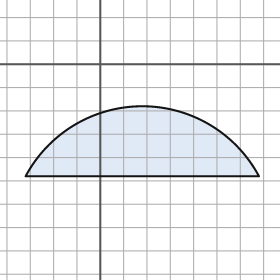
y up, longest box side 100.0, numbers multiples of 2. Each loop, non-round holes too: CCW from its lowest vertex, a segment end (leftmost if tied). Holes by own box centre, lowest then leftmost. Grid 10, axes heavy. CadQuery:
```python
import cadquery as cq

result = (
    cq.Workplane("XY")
    .moveTo(-32.0, -48.0)
    .lineTo(68.0, -48.0)
    .threePointArc((18.0, -18.0), (-32.0, -48.0))
    .close()
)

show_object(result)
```